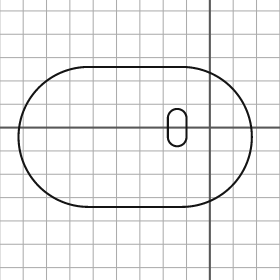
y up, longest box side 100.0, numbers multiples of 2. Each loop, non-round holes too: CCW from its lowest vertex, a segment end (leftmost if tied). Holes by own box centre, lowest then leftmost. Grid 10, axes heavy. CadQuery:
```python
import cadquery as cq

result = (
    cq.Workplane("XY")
    .moveTo(-52.0, -34.0)
    .lineTo(-12.0, -34.0)
    .threePointArc((18.0, -4.0), (-12.0, 26.0))
    .lineTo(-52.0, 26.0)
    .threePointArc((-82.0, -4.0), (-52.0, -34.0))
    .close()
    .moveTo(-18.0, -4.0)
    .threePointArc((-14.0, -8.0), (-10.0, -4.0))
    .lineTo(-10.0, 4.0)
    .threePointArc((-14.0, 8.0), (-18.0, 4.0))
    .close()
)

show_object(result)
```